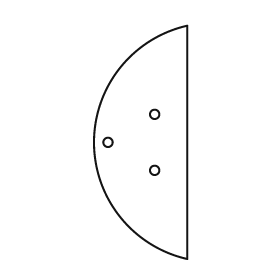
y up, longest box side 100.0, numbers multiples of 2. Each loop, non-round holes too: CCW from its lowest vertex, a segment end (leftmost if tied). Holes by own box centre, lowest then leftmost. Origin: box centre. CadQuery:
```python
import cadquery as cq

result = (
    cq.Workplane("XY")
    .moveTo(20.0, -50.0)
    .lineTo(20.0, 50.0)
    .threePointArc((-20.0, 0.0), (20.0, -50.0))
    .close()
    .moveTo(6.0, -12.0)
    .circle(2.0)
    .moveTo(-14.0, 0.0)
    .circle(2.0)
    .moveTo(6.0, 12.0)
    .circle(2.0)
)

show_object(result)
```